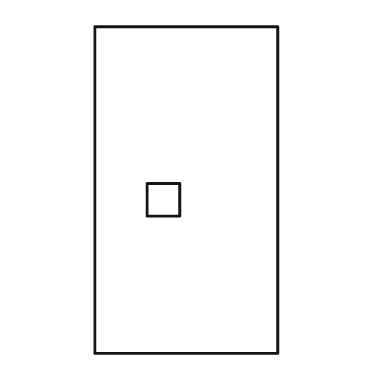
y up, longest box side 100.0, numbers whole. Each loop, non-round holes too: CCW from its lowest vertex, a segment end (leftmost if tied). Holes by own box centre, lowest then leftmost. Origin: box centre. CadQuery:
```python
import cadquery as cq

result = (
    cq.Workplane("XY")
    .moveTo(-28.0, -50.0)
    .lineTo(28.0, -50.0)
    .lineTo(28.0, 50.0)
    .lineTo(-28.0, 50.0)
    .close()
    .moveTo(-12.0, -8.0)
    .lineTo(-2.0, -8.0)
    .lineTo(-2.0, 2.0)
    .lineTo(-12.0, 2.0)
    .close()
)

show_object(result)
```